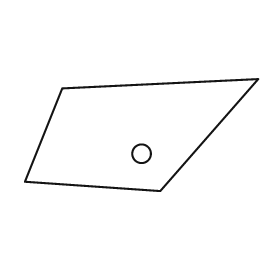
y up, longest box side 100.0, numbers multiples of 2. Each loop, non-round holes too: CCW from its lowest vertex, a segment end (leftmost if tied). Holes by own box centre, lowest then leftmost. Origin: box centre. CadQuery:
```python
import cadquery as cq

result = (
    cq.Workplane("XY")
    .moveTo(8.0, -24.0)
    .lineTo(50.0, 24.0)
    .lineTo(-34.0, 20.0)
    .lineTo(-50.0, -20.0)
    .close()
    .moveTo(0.0, -8.0)
    .circle(4.0)
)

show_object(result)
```